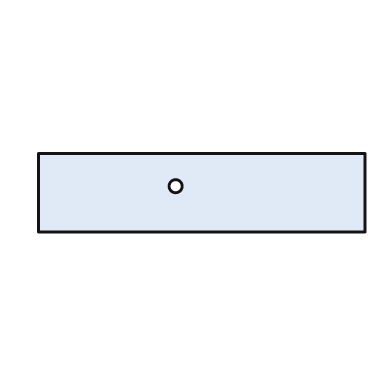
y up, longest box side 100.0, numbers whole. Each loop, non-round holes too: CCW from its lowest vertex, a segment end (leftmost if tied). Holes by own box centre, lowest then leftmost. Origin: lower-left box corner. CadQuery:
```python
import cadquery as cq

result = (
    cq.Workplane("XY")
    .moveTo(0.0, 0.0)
    .lineTo(100.0, 0.0)
    .lineTo(100.0, 24.0)
    .lineTo(0.0, 24.0)
    .close()
    .moveTo(42.0, 14.0)
    .circle(2.0)
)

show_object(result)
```